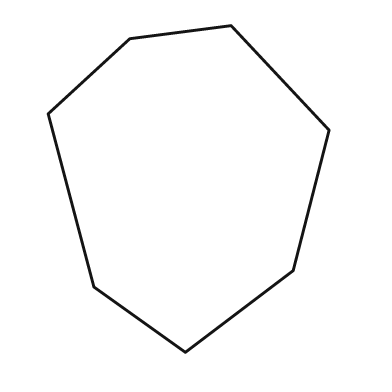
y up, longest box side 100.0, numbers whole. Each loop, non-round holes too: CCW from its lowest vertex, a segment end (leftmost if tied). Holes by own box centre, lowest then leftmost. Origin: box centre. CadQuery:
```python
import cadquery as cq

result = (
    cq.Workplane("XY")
    .moveTo(-1.0, -50.0)
    .lineTo(32.0, -25.0)
    .lineTo(43.0, 18.0)
    .lineTo(13.0, 50.0)
    .lineTo(-18.0, 46.0)
    .lineTo(-43.0, 23.0)
    .lineTo(-29.0, -30.0)
    .close()
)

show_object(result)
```